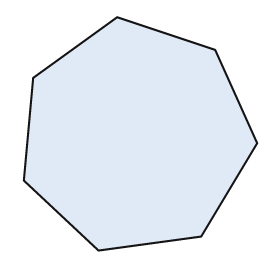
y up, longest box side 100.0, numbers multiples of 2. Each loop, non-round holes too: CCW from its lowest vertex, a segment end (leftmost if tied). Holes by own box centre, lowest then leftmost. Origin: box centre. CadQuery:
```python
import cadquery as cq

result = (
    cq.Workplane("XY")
    .moveTo(-18.0, -50.0)
    .lineTo(26.0, -44.0)
    .lineTo(50.0, -4.0)
    .lineTo(32.0, 36.0)
    .lineTo(-10.0, 50.0)
    .lineTo(-46.0, 24.0)
    .lineTo(-50.0, -20.0)
    .close()
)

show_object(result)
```